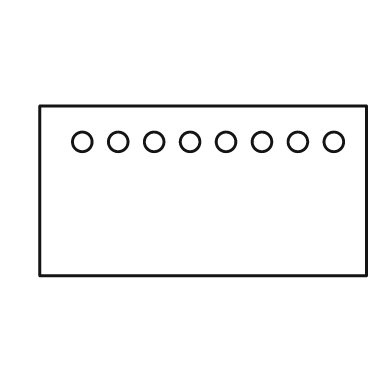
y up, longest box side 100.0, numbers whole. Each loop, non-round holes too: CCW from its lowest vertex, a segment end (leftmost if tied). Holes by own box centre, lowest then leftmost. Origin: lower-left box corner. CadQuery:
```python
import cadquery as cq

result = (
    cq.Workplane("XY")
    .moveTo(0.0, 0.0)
    .lineTo(100.0, 0.0)
    .lineTo(100.0, 52.0)
    .lineTo(0.0, 52.0)
    .close()
    .moveTo(13.0, 41.0)
    .circle(3.0)
    .moveTo(24.0, 41.0)
    .circle(3.0)
    .moveTo(35.0, 41.0)
    .circle(3.0)
    .moveTo(46.0, 41.0)
    .circle(3.0)
    .moveTo(57.0, 41.0)
    .circle(3.0)
    .moveTo(68.0, 41.0)
    .circle(3.0)
    .moveTo(79.0, 41.0)
    .circle(3.0)
    .moveTo(90.0, 41.0)
    .circle(3.0)
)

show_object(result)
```